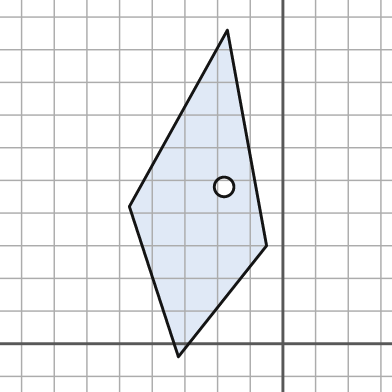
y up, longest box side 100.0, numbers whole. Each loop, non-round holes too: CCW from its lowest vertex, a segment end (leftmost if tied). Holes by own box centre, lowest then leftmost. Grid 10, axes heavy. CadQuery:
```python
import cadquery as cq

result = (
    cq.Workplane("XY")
    .moveTo(-32.0, -4.0)
    .lineTo(-5.0, 30.0)
    .lineTo(-17.0, 96.0)
    .lineTo(-47.0, 42.0)
    .close()
    .moveTo(-18.0, 48.0)
    .circle(3.0)
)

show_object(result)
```